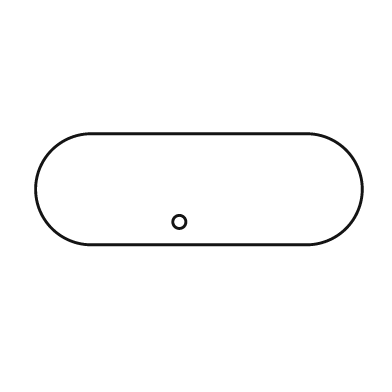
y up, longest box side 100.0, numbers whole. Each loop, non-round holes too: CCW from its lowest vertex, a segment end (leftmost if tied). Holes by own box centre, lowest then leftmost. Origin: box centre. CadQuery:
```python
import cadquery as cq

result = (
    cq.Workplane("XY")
    .moveTo(-33.0, -17.0)
    .lineTo(33.0, -17.0)
    .threePointArc((50.0, 0.0), (33.0, 17.0))
    .lineTo(-33.0, 17.0)
    .threePointArc((-50.0, 0.0), (-33.0, -17.0))
    .close()
    .moveTo(-6.0, -10.0)
    .circle(2.0)
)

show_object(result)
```